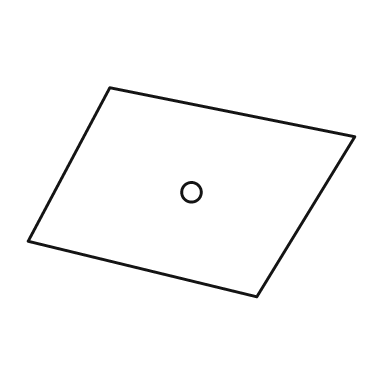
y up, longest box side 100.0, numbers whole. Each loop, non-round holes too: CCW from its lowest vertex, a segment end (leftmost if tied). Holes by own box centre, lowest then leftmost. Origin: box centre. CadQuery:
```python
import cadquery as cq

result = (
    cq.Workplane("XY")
    .moveTo(20.0, -32.0)
    .lineTo(50.0, 17.0)
    .lineTo(-25.0, 32.0)
    .lineTo(-50.0, -15.0)
    .close()
    .moveTo(0.0, 0.0)
    .circle(3.0)
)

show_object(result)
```